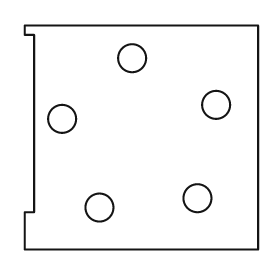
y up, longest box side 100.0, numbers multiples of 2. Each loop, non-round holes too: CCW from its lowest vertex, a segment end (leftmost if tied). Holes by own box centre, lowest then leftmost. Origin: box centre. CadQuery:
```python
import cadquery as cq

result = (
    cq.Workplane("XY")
    .moveTo(-50.0, -48.0)
    .lineTo(50.0, -48.0)
    .lineTo(50.0, 48.0)
    .lineTo(-50.0, 48.0)
    .lineTo(-50.0, 44.0)
    .lineTo(-46.0, 44.0)
    .lineTo(-46.0, -32.0)
    .lineTo(-50.0, -32.0)
    .close()
    .moveTo(-18.0, -30.0)
    .circle(6.0)
    .moveTo(24.0, -26.0)
    .circle(6.0)
    .moveTo(-34.0, 8.0)
    .circle(6.0)
    .moveTo(32.0, 14.0)
    .circle(6.0)
    .moveTo(-4.0, 34.0)
    .circle(6.0)
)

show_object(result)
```